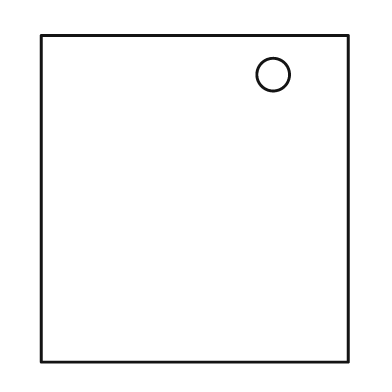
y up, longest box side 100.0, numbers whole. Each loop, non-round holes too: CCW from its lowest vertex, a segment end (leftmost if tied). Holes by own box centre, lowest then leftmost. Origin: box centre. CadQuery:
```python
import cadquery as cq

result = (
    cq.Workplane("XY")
    .moveTo(-47.0, -50.0)
    .lineTo(47.0, -50.0)
    .lineTo(47.0, 50.0)
    .lineTo(-47.0, 50.0)
    .close()
    .moveTo(24.0, 38.0)
    .circle(5.0)
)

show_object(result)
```